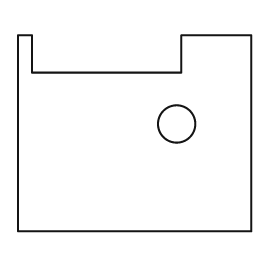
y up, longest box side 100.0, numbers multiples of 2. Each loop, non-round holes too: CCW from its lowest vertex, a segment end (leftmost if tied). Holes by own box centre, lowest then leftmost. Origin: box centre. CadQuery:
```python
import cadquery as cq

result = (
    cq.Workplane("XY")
    .moveTo(-50.0, -42.0)
    .lineTo(50.0, -42.0)
    .lineTo(50.0, 42.0)
    .lineTo(20.0, 42.0)
    .lineTo(20.0, 26.0)
    .lineTo(-44.0, 26.0)
    .lineTo(-44.0, 42.0)
    .lineTo(-50.0, 42.0)
    .close()
    .moveTo(18.0, 4.0)
    .circle(8.0)
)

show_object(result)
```